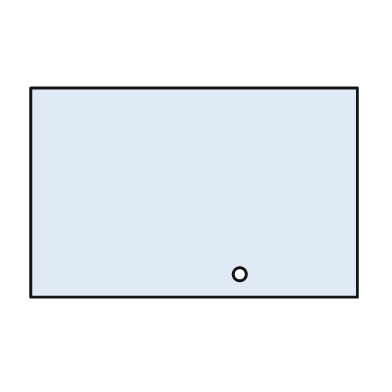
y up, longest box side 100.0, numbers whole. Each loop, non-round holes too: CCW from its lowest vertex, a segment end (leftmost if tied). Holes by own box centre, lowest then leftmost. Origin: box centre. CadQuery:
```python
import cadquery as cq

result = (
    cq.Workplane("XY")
    .moveTo(-50.0, -32.0)
    .lineTo(50.0, -32.0)
    .lineTo(50.0, 32.0)
    .lineTo(-50.0, 32.0)
    .close()
    .moveTo(14.0, -25.0)
    .circle(2.0)
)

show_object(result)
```